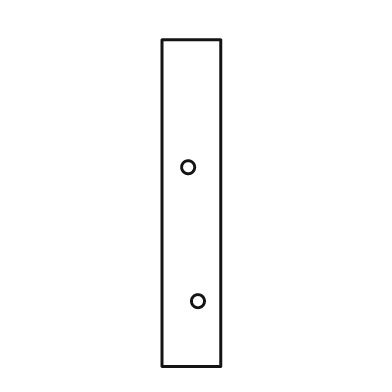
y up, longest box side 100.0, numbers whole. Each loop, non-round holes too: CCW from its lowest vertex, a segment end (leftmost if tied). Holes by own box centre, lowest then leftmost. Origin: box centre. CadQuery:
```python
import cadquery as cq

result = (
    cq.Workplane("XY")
    .moveTo(-9.0, -50.0)
    .lineTo(9.0, -50.0)
    .lineTo(9.0, 50.0)
    .lineTo(-9.0, 50.0)
    .close()
    .moveTo(2.0, -30.0)
    .circle(2.0)
    .moveTo(-1.0, 11.0)
    .circle(2.0)
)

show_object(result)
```